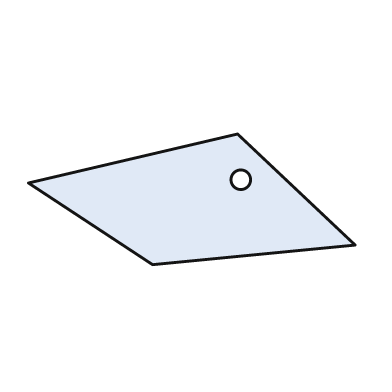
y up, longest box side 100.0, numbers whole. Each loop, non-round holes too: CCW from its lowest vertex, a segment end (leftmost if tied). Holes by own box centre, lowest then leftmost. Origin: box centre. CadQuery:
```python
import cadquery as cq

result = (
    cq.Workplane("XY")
    .moveTo(-12.0, -20.0)
    .lineTo(50.0, -14.0)
    .lineTo(14.0, 20.0)
    .lineTo(-50.0, 5.0)
    .close()
    .moveTo(15.0, 6.0)
    .circle(3.0)
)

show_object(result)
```